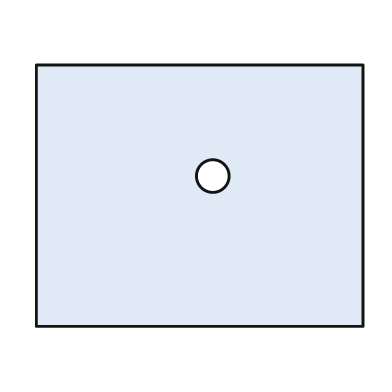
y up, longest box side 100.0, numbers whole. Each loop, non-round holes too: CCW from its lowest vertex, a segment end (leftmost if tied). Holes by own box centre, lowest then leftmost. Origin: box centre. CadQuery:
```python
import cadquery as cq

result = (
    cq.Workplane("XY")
    .moveTo(-50.0, -40.0)
    .lineTo(50.0, -40.0)
    .lineTo(50.0, 40.0)
    .lineTo(-50.0, 40.0)
    .close()
    .moveTo(4.0, 6.0)
    .circle(5.0)
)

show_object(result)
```